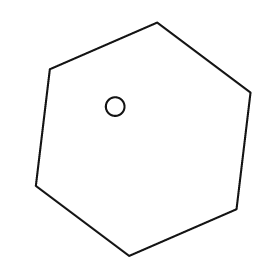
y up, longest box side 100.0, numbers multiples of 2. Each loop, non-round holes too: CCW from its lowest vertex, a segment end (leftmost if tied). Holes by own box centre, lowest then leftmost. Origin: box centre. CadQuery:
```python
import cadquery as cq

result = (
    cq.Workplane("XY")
    .moveTo(-6.0, -50.0)
    .lineTo(40.0, -30.0)
    .lineTo(46.0, 20.0)
    .lineTo(6.0, 50.0)
    .lineTo(-40.0, 30.0)
    .lineTo(-46.0, -20.0)
    .close()
    .moveTo(-12.0, 14.0)
    .circle(4.0)
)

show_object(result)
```